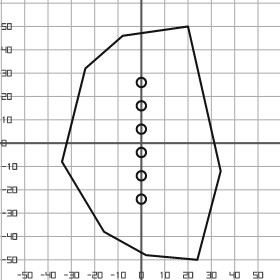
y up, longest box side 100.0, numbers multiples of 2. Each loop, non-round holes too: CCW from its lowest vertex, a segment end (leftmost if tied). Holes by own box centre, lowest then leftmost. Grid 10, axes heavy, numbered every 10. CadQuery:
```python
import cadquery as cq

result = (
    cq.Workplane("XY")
    .moveTo(24.0, -50.0)
    .lineTo(34.0, -12.0)
    .lineTo(20.0, 50.0)
    .lineTo(-8.0, 46.0)
    .lineTo(-24.0, 32.0)
    .lineTo(-34.0, -8.0)
    .lineTo(-16.0, -38.0)
    .lineTo(2.0, -48.0)
    .close()
    .moveTo(0.0, -24.0)
    .circle(2.0)
    .moveTo(0.0, -14.0)
    .circle(2.0)
    .moveTo(0.0, -4.0)
    .circle(2.0)
    .moveTo(0.0, 6.0)
    .circle(2.0)
    .moveTo(0.0, 16.0)
    .circle(2.0)
    .moveTo(0.0, 26.0)
    .circle(2.0)
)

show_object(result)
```